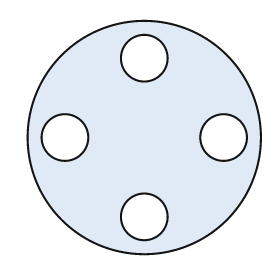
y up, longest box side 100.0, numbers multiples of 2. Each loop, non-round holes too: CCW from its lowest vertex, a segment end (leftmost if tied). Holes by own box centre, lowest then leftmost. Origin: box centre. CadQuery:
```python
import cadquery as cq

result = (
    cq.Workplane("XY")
    .moveTo(0.0, 0.0)
    .circle(50.0)
    .moveTo(0.0, -34.0)
    .circle(10.0)
    .moveTo(-34.0, 0.0)
    .circle(10.0)
    .moveTo(34.0, 0.0)
    .circle(10.0)
    .moveTo(0.0, 34.0)
    .circle(10.0)
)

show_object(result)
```